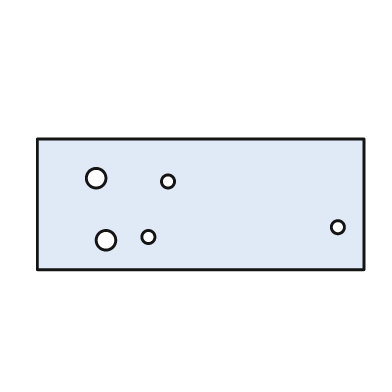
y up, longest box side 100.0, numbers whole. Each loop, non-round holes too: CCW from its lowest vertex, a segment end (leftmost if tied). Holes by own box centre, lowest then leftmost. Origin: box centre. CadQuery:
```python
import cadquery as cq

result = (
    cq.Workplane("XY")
    .moveTo(-50.0, -20.0)
    .lineTo(50.0, -20.0)
    .lineTo(50.0, 20.0)
    .lineTo(-50.0, 20.0)
    .close()
    .moveTo(-29.0, -11.0)
    .circle(3.0)
    .moveTo(-16.0, -10.0)
    .circle(2.0)
    .moveTo(42.0, -7.0)
    .circle(2.0)
    .moveTo(-10.0, 7.0)
    .circle(2.0)
    .moveTo(-32.0, 8.0)
    .circle(3.0)
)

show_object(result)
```